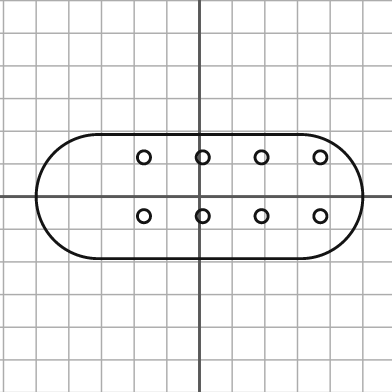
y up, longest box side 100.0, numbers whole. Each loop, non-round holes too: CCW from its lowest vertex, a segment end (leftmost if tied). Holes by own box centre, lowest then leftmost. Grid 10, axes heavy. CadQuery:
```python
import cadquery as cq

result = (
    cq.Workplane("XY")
    .moveTo(-31.0, -19.0)
    .lineTo(31.0, -19.0)
    .threePointArc((50.0, 0.0), (31.0, 19.0))
    .lineTo(-31.0, 19.0)
    .threePointArc((-50.0, 0.0), (-31.0, -19.0))
    .close()
    .moveTo(-17.0, -6.0)
    .circle(2.0)
    .moveTo(1.0, -6.0)
    .circle(2.0)
    .moveTo(19.0, -6.0)
    .circle(2.0)
    .moveTo(37.0, -6.0)
    .circle(2.0)
    .moveTo(-17.0, 12.0)
    .circle(2.0)
    .moveTo(1.0, 12.0)
    .circle(2.0)
    .moveTo(19.0, 12.0)
    .circle(2.0)
    .moveTo(37.0, 12.0)
    .circle(2.0)
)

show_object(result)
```